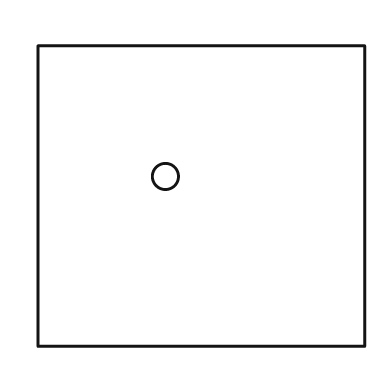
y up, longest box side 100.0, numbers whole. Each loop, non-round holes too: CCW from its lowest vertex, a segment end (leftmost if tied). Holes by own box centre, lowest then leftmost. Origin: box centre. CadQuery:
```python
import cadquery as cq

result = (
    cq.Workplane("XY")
    .moveTo(-50.0, -46.0)
    .lineTo(50.0, -46.0)
    .lineTo(50.0, 46.0)
    .lineTo(-50.0, 46.0)
    .close()
    .moveTo(-11.0, 6.0)
    .circle(4.0)
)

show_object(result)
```